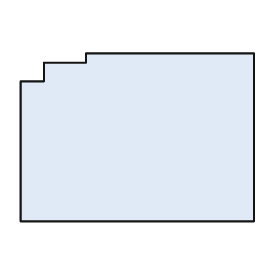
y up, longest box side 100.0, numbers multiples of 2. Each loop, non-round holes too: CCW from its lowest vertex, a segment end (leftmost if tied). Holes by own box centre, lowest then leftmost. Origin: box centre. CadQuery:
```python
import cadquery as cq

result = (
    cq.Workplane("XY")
    .moveTo(-50.0, -36.0)
    .lineTo(50.0, -36.0)
    .lineTo(50.0, 36.0)
    .lineTo(-22.0, 36.0)
    .lineTo(-22.0, 32.0)
    .lineTo(-40.0, 32.0)
    .lineTo(-40.0, 24.0)
    .lineTo(-50.0, 24.0)
    .close()
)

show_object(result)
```